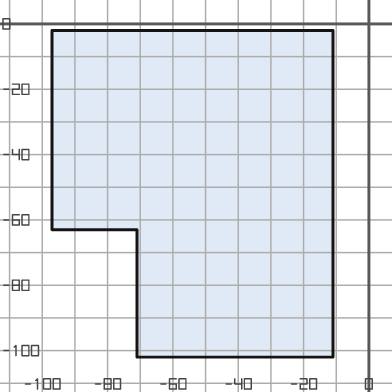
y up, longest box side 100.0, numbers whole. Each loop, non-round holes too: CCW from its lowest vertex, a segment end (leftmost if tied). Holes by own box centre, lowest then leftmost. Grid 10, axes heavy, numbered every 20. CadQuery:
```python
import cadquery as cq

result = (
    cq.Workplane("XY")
    .moveTo(-71.0, -102.0)
    .lineTo(-11.0, -102.0)
    .lineTo(-11.0, -2.0)
    .lineTo(-97.0, -2.0)
    .lineTo(-97.0, -63.0)
    .lineTo(-71.0, -63.0)
    .close()
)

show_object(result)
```